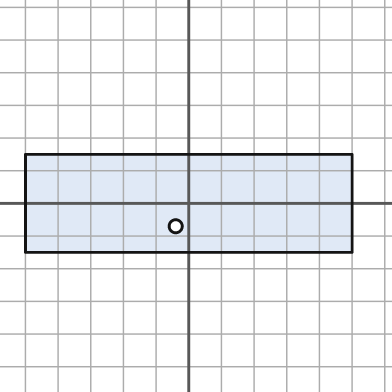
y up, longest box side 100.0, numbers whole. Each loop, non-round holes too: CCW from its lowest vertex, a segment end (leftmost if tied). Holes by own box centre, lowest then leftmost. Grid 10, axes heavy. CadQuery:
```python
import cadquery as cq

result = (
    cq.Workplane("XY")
    .moveTo(-50.0, -15.0)
    .lineTo(50.0, -15.0)
    .lineTo(50.0, 15.0)
    .lineTo(-50.0, 15.0)
    .close()
    .moveTo(-4.0, -7.0)
    .circle(2.0)
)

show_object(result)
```